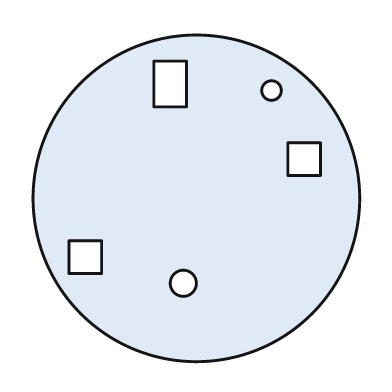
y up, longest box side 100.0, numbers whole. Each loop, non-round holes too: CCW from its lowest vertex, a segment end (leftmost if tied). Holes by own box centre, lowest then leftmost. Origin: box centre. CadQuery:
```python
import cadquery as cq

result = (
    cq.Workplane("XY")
    .moveTo(0.0, 0.0)
    .circle(50.0)
    .moveTo(-4.0, -26.0)
    .circle(4.0)
    .moveTo(-39.0, -23.0)
    .lineTo(-29.0, -23.0)
    .lineTo(-29.0, -13.0)
    .lineTo(-39.0, -13.0)
    .close()
    .moveTo(28.0, 7.0)
    .lineTo(38.0, 7.0)
    .lineTo(38.0, 17.0)
    .lineTo(28.0, 17.0)
    .close()
    .moveTo(23.0, 33.0)
    .circle(3.0)
    .moveTo(-13.0, 28.0)
    .lineTo(-3.0, 28.0)
    .lineTo(-3.0, 42.0)
    .lineTo(-13.0, 42.0)
    .close()
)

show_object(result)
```